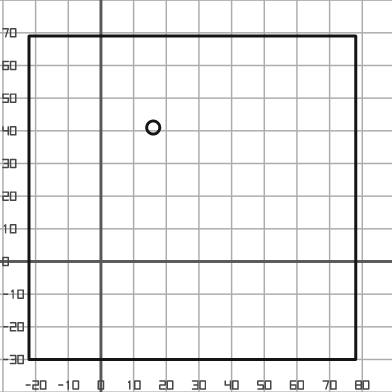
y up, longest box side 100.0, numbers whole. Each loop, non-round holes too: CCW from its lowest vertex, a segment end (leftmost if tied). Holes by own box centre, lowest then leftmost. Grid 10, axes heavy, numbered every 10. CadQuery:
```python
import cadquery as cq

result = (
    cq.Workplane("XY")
    .moveTo(-22.0, -30.0)
    .lineTo(78.0, -30.0)
    .lineTo(78.0, 69.0)
    .lineTo(-22.0, 69.0)
    .close()
    .moveTo(16.0, 41.0)
    .circle(2.0)
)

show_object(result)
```